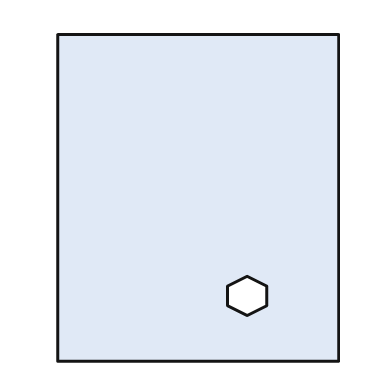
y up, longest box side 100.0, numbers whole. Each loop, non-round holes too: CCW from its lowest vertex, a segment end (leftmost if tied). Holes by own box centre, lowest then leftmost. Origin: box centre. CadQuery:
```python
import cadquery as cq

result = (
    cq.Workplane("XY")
    .moveTo(-43.0, -50.0)
    .lineTo(43.0, -50.0)
    .lineTo(43.0, 50.0)
    .lineTo(-43.0, 50.0)
    .close()
    .moveTo(15.0, -36.0)
    .lineTo(21.0, -33.0)
    .lineTo(21.0, -27.0)
    .lineTo(15.0, -24.0)
    .lineTo(9.0, -27.0)
    .lineTo(9.0, -33.0)
    .close()
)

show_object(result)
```